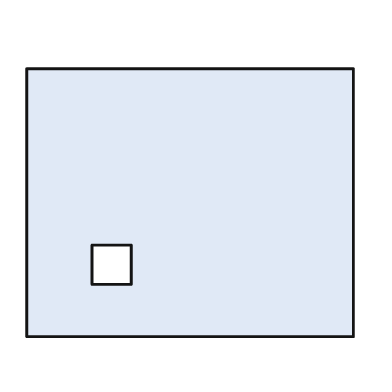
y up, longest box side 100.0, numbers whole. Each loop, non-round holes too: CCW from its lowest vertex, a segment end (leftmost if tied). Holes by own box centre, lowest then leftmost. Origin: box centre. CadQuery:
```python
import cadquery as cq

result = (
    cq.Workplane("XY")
    .moveTo(-50.0, -41.0)
    .lineTo(50.0, -41.0)
    .lineTo(50.0, 41.0)
    .lineTo(-50.0, 41.0)
    .close()
    .moveTo(-30.0, -25.0)
    .lineTo(-18.0, -25.0)
    .lineTo(-18.0, -13.0)
    .lineTo(-30.0, -13.0)
    .close()
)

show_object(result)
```